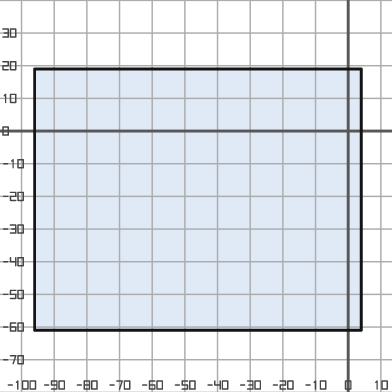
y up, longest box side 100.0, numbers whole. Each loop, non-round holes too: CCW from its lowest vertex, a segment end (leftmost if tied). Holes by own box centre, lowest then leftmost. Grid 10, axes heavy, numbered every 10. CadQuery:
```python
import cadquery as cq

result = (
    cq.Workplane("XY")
    .moveTo(-96.0, -61.0)
    .lineTo(4.0, -61.0)
    .lineTo(4.0, 19.0)
    .lineTo(-96.0, 19.0)
    .close()
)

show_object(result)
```